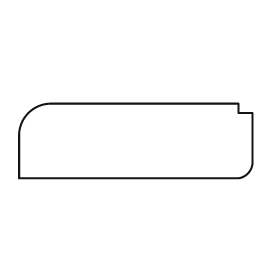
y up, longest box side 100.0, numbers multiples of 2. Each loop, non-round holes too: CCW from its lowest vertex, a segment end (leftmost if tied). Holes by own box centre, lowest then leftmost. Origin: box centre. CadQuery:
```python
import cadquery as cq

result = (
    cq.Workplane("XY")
    .moveTo(-50.0, -16.0)
    .lineTo(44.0, -16.0)
    .threePointArc((48.0, -14.0), (50.0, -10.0))
    .lineTo(50.0, 12.0)
    .lineTo(44.0, 12.0)
    .lineTo(44.0, 16.0)
    .lineTo(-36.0, 16.0)
    .threePointArc((-46.0, 12.0), (-50.0, 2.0))
    .close()
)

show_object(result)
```